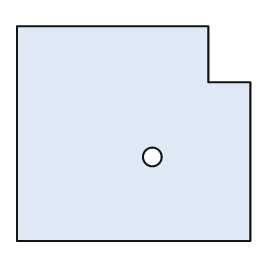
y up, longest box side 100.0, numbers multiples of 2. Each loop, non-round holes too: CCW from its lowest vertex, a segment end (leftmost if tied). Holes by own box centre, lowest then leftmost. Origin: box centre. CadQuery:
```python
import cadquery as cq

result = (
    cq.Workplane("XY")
    .moveTo(-50.0, -46.0)
    .lineTo(50.0, -46.0)
    .lineTo(50.0, 22.0)
    .lineTo(32.0, 22.0)
    .lineTo(32.0, 46.0)
    .lineTo(-50.0, 46.0)
    .close()
    .moveTo(8.0, -10.0)
    .circle(4.0)
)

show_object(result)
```